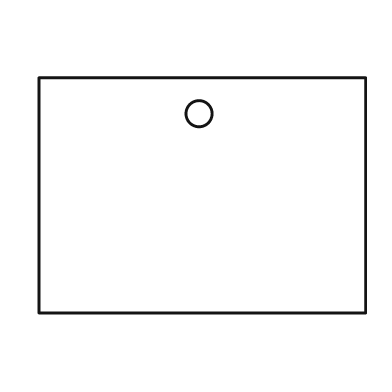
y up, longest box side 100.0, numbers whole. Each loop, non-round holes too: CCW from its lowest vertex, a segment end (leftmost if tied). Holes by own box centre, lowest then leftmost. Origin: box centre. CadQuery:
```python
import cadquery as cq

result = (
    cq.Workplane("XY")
    .moveTo(-50.0, -36.0)
    .lineTo(50.0, -36.0)
    .lineTo(50.0, 36.0)
    .lineTo(-50.0, 36.0)
    .close()
    .moveTo(-1.0, 25.0)
    .circle(4.0)
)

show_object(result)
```